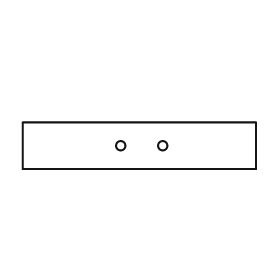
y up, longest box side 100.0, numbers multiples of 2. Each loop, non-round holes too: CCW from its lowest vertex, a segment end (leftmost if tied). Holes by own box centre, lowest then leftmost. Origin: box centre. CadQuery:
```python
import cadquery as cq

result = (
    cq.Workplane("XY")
    .moveTo(-50.0, -10.0)
    .lineTo(50.0, -10.0)
    .lineTo(50.0, 10.0)
    .lineTo(-50.0, 10.0)
    .close()
    .moveTo(-8.0, 0.0)
    .circle(2.0)
    .moveTo(10.0, 0.0)
    .circle(2.0)
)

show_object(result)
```